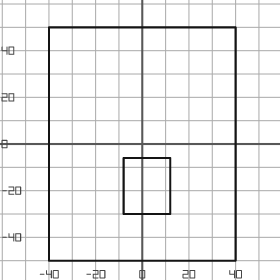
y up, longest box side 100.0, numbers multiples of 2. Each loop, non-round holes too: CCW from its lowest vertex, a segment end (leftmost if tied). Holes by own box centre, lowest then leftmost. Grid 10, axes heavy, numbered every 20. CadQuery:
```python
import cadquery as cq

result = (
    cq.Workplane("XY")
    .moveTo(-40.0, -50.0)
    .lineTo(40.0, -50.0)
    .lineTo(40.0, 50.0)
    .lineTo(-40.0, 50.0)
    .close()
    .moveTo(-8.0, -30.0)
    .lineTo(12.0, -30.0)
    .lineTo(12.0, -6.0)
    .lineTo(-8.0, -6.0)
    .close()
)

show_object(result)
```